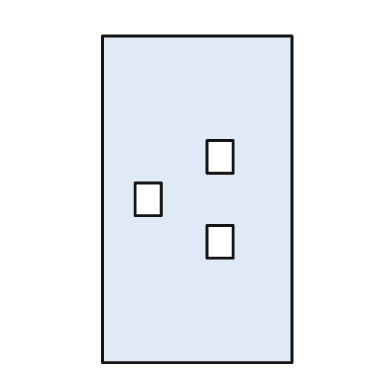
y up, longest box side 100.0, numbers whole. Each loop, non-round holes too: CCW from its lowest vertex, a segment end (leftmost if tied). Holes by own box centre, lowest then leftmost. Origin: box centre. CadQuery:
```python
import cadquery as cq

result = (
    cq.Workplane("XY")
    .moveTo(-29.0, -50.0)
    .lineTo(29.0, -50.0)
    .lineTo(29.0, 50.0)
    .lineTo(-29.0, 50.0)
    .close()
    .moveTo(3.0, -18.0)
    .lineTo(11.0, -18.0)
    .lineTo(11.0, -8.0)
    .lineTo(3.0, -8.0)
    .close()
    .moveTo(-19.0, -5.0)
    .lineTo(-11.0, -5.0)
    .lineTo(-11.0, 5.0)
    .lineTo(-19.0, 5.0)
    .close()
    .moveTo(3.0, 8.0)
    .lineTo(11.0, 8.0)
    .lineTo(11.0, 18.0)
    .lineTo(3.0, 18.0)
    .close()
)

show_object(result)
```